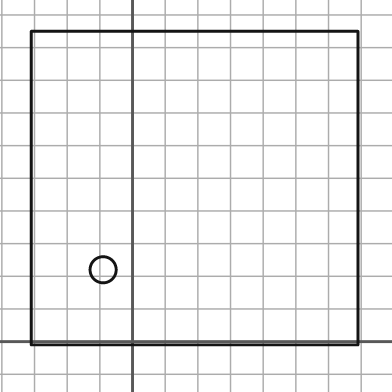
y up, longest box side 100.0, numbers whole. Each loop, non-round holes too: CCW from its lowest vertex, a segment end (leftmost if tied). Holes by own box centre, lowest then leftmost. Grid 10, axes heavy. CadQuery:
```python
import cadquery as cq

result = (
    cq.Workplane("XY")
    .moveTo(-31.0, -1.0)
    .lineTo(69.0, -1.0)
    .lineTo(69.0, 95.0)
    .lineTo(-31.0, 95.0)
    .close()
    .moveTo(-9.0, 22.0)
    .circle(4.0)
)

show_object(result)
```